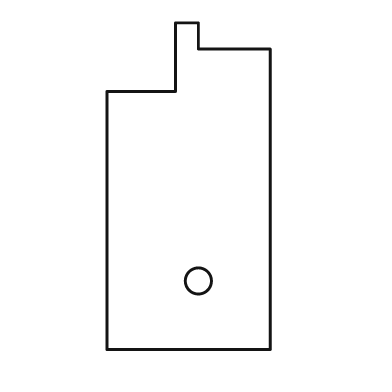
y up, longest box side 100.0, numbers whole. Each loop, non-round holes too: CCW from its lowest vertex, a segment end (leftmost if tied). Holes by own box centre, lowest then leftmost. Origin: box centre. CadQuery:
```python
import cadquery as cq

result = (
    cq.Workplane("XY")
    .moveTo(-25.0, -50.0)
    .lineTo(25.0, -50.0)
    .lineTo(25.0, 42.0)
    .lineTo(3.0, 42.0)
    .lineTo(3.0, 50.0)
    .lineTo(-4.0, 50.0)
    .lineTo(-4.0, 29.0)
    .lineTo(-25.0, 29.0)
    .close()
    .moveTo(3.0, -29.0)
    .circle(4.0)
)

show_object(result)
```